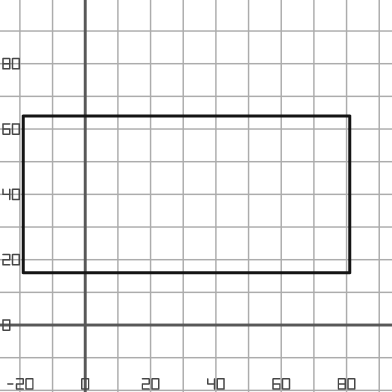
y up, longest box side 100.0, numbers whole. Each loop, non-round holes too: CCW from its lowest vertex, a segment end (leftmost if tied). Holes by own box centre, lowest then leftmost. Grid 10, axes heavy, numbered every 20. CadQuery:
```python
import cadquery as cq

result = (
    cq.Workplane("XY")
    .moveTo(-19.0, 16.0)
    .lineTo(81.0, 16.0)
    .lineTo(81.0, 64.0)
    .lineTo(-19.0, 64.0)
    .close()
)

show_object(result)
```